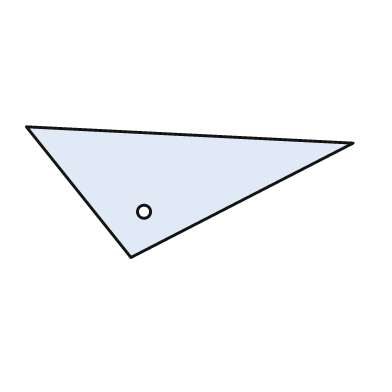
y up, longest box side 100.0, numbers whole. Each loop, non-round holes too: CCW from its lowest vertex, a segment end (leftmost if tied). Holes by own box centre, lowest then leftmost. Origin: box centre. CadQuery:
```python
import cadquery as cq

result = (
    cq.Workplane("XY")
    .moveTo(-18.0, -20.0)
    .lineTo(50.0, 15.0)
    .lineTo(-50.0, 20.0)
    .close()
    .moveTo(-14.0, -6.0)
    .circle(2.0)
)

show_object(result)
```